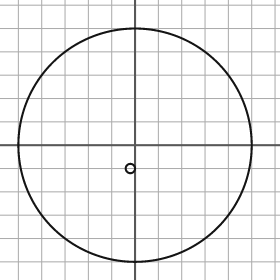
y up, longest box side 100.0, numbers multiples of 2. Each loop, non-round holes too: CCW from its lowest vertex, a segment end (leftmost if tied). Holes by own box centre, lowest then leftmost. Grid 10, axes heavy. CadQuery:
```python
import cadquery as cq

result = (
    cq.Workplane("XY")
    .moveTo(0.0, 0.0)
    .circle(50.0)
    .moveTo(-2.0, -10.0)
    .circle(2.0)
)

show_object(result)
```